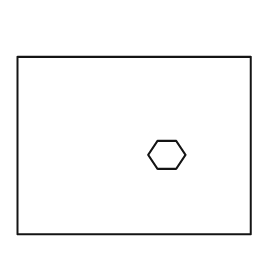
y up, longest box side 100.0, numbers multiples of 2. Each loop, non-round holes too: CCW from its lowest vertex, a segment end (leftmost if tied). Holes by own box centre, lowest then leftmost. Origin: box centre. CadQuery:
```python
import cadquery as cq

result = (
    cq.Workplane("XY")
    .moveTo(-50.0, -38.0)
    .lineTo(50.0, -38.0)
    .lineTo(50.0, 38.0)
    .lineTo(-50.0, 38.0)
    .close()
    .moveTo(10.0, -10.0)
    .lineTo(18.0, -10.0)
    .lineTo(22.0, -4.0)
    .lineTo(18.0, 2.0)
    .lineTo(10.0, 2.0)
    .lineTo(6.0, -4.0)
    .close()
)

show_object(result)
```